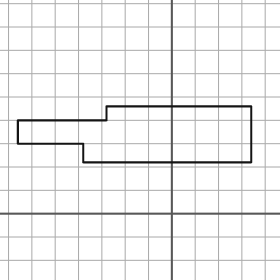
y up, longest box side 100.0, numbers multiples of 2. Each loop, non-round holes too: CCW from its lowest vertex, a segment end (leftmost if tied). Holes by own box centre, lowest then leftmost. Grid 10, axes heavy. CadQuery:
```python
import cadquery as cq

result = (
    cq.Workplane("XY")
    .moveTo(-38.0, 22.0)
    .lineTo(34.0, 22.0)
    .lineTo(34.0, 46.0)
    .lineTo(-28.0, 46.0)
    .lineTo(-28.0, 40.0)
    .lineTo(-66.0, 40.0)
    .lineTo(-66.0, 30.0)
    .lineTo(-38.0, 30.0)
    .close()
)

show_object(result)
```